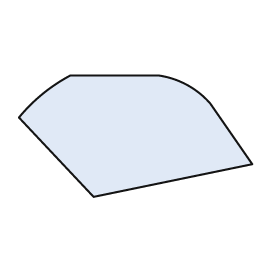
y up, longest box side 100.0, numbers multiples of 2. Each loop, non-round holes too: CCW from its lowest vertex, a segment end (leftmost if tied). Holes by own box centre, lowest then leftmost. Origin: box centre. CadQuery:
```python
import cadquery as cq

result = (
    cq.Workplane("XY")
    .moveTo(-18.0, -26.0)
    .lineTo(50.0, -12.0)
    .lineTo(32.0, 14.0)
    .threePointArc((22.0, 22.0), (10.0, 26.0))
    .lineTo(-28.0, 26.0)
    .threePointArc((-40.0, 18.0), (-50.0, 8.0))
    .close()
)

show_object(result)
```